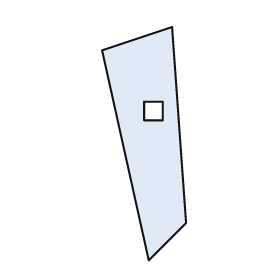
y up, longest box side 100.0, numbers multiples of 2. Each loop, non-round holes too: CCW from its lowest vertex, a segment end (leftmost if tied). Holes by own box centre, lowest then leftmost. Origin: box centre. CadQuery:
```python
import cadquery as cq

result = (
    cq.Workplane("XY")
    .moveTo(2.0, -50.0)
    .lineTo(18.0, -34.0)
    .lineTo(12.0, 50.0)
    .lineTo(-18.0, 40.0)
    .close()
    .moveTo(0.0, 10.0)
    .lineTo(8.0, 10.0)
    .lineTo(8.0, 18.0)
    .lineTo(0.0, 18.0)
    .close()
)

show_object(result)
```